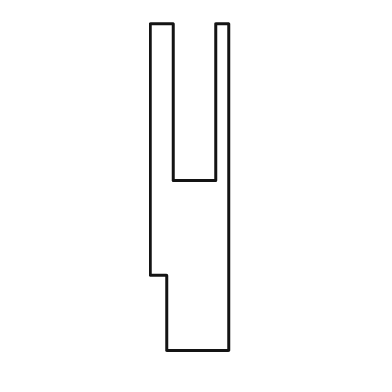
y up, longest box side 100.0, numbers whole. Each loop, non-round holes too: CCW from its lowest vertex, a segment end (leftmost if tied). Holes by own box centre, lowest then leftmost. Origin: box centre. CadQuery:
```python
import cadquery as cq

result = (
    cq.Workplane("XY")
    .moveTo(-7.0, -50.0)
    .lineTo(12.0, -50.0)
    .lineTo(12.0, 50.0)
    .lineTo(8.0, 50.0)
    .lineTo(8.0, 2.0)
    .lineTo(-5.0, 2.0)
    .lineTo(-5.0, 50.0)
    .lineTo(-12.0, 50.0)
    .lineTo(-12.0, -27.0)
    .lineTo(-7.0, -27.0)
    .close()
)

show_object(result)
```